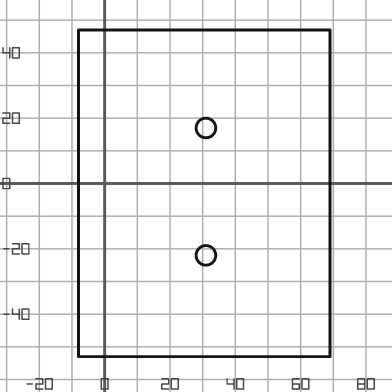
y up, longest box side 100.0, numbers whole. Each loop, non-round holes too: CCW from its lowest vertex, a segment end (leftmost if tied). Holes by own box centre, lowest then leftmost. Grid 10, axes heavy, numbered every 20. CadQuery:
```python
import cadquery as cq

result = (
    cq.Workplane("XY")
    .moveTo(-8.0, -53.0)
    .lineTo(69.0, -53.0)
    .lineTo(69.0, 47.0)
    .lineTo(-8.0, 47.0)
    .close()
    .moveTo(31.0, -22.0)
    .circle(3.0)
    .moveTo(31.0, 17.0)
    .circle(3.0)
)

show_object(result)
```